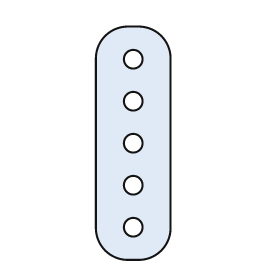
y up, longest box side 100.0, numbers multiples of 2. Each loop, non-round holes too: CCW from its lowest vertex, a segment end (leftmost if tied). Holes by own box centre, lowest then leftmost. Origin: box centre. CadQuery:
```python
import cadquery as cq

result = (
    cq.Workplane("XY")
    .moveTo(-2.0, -50.0)
    .lineTo(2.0, -50.0)
    .threePointArc((12.0, -46.0), (16.0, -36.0))
    .lineTo(16.0, 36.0)
    .threePointArc((12.0, 46.0), (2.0, 50.0))
    .lineTo(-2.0, 50.0)
    .threePointArc((-12.0, 46.0), (-16.0, 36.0))
    .lineTo(-16.0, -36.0)
    .threePointArc((-12.0, -46.0), (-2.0, -50.0))
    .close()
    .moveTo(0.0, -36.0)
    .circle(4.0)
    .moveTo(0.0, -18.0)
    .circle(4.0)
    .moveTo(0.0, 0.0)
    .circle(4.0)
    .moveTo(0.0, 18.0)
    .circle(4.0)
    .moveTo(0.0, 36.0)
    .circle(4.0)
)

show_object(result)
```